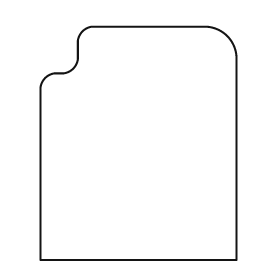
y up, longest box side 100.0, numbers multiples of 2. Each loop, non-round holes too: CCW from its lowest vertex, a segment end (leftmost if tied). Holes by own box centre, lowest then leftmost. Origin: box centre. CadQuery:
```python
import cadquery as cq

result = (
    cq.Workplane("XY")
    .moveTo(-42.0, -50.0)
    .lineTo(42.0, -50.0)
    .lineTo(42.0, 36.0)
    .threePointArc((38.0, 46.0), (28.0, 50.0))
    .lineTo(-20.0, 50.0)
    .threePointArc((-24.0, 48.0), (-26.0, 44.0))
    .lineTo(-26.0, 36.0)
    .threePointArc((-28.0, 32.0), (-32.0, 30.0))
    .lineTo(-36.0, 30.0)
    .threePointArc((-40.0, 28.0), (-42.0, 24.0))
    .close()
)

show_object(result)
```